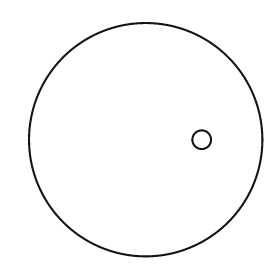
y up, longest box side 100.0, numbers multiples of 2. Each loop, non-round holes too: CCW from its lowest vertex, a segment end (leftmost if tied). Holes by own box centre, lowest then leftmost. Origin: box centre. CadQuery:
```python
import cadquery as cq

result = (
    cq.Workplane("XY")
    .moveTo(0.0, 0.0)
    .circle(50.0)
    .moveTo(24.0, 0.0)
    .circle(4.0)
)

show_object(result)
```